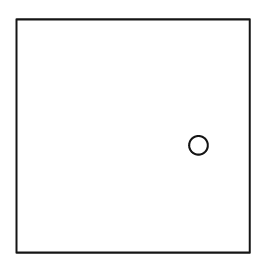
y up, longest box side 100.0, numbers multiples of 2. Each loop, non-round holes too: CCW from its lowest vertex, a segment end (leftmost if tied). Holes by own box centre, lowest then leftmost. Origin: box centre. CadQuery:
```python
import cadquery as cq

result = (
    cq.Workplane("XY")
    .moveTo(-50.0, -50.0)
    .lineTo(50.0, -50.0)
    .lineTo(50.0, 50.0)
    .lineTo(-50.0, 50.0)
    .close()
    .moveTo(28.0, -4.0)
    .circle(4.0)
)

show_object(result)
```